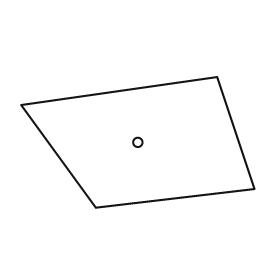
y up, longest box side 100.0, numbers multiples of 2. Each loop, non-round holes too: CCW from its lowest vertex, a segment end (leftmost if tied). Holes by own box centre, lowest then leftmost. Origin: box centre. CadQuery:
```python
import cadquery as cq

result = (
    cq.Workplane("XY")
    .moveTo(-18.0, -28.0)
    .lineTo(50.0, -20.0)
    .lineTo(34.0, 28.0)
    .lineTo(-50.0, 16.0)
    .close()
    .moveTo(0.0, 0.0)
    .circle(2.0)
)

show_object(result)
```